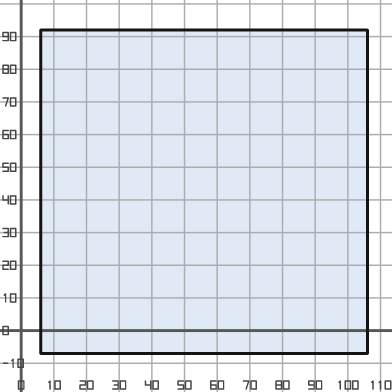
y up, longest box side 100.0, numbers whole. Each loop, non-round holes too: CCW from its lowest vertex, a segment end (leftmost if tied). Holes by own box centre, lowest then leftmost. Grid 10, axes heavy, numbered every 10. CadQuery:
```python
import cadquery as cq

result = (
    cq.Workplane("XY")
    .moveTo(6.0, -7.0)
    .lineTo(106.0, -7.0)
    .lineTo(106.0, 92.0)
    .lineTo(6.0, 92.0)
    .close()
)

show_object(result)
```